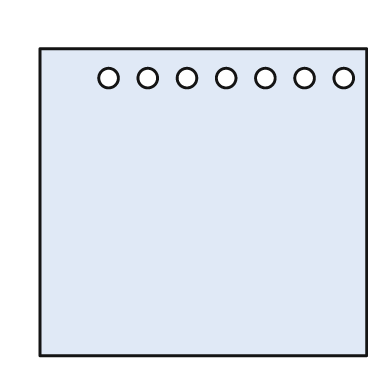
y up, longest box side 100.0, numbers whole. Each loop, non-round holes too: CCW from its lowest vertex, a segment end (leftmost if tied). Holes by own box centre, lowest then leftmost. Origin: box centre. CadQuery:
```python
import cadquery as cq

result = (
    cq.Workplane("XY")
    .moveTo(-50.0, -47.0)
    .lineTo(50.0, -47.0)
    .lineTo(50.0, 47.0)
    .lineTo(-50.0, 47.0)
    .close()
    .moveTo(-29.0, 38.0)
    .circle(3.0)
    .moveTo(-17.0, 38.0)
    .circle(3.0)
    .moveTo(-5.0, 38.0)
    .circle(3.0)
    .moveTo(7.0, 38.0)
    .circle(3.0)
    .moveTo(19.0, 38.0)
    .circle(3.0)
    .moveTo(31.0, 38.0)
    .circle(3.0)
    .moveTo(43.0, 38.0)
    .circle(3.0)
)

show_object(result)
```